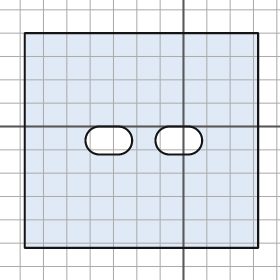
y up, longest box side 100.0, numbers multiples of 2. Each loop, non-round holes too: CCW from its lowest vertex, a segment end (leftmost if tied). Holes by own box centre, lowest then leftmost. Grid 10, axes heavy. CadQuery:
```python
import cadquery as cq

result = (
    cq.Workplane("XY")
    .moveTo(-68.0, -52.0)
    .lineTo(32.0, -52.0)
    .lineTo(32.0, 40.0)
    .lineTo(-68.0, 40.0)
    .close()
    .moveTo(-36.0, -12.0)
    .lineTo(-28.0, -12.0)
    .threePointArc((-22.0, -6.0), (-28.0, 0.0))
    .lineTo(-36.0, 0.0)
    .threePointArc((-42.0, -6.0), (-36.0, -12.0))
    .close()
    .moveTo(-6.0, -12.0)
    .lineTo(2.0, -12.0)
    .threePointArc((8.0, -6.0), (2.0, 0.0))
    .lineTo(-6.0, 0.0)
    .threePointArc((-12.0, -6.0), (-6.0, -12.0))
    .close()
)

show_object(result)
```